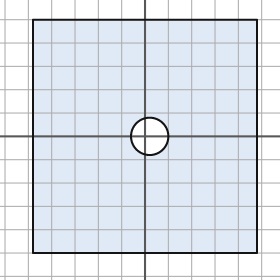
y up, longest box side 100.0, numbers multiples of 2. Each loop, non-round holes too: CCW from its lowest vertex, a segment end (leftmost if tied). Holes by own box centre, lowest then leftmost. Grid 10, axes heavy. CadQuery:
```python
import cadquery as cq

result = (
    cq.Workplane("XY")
    .moveTo(-48.0, -50.0)
    .lineTo(48.0, -50.0)
    .lineTo(48.0, 50.0)
    .lineTo(-48.0, 50.0)
    .close()
    .moveTo(2.0, 0.0)
    .circle(8.0)
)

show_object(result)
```